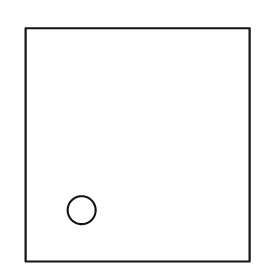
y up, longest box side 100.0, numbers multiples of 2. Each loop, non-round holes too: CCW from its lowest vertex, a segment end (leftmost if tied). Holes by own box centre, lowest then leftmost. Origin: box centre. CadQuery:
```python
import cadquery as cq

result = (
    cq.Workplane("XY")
    .moveTo(-48.0, -50.0)
    .lineTo(48.0, -50.0)
    .lineTo(48.0, 50.0)
    .lineTo(-48.0, 50.0)
    .close()
    .moveTo(-24.0, -28.0)
    .circle(6.0)
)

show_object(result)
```